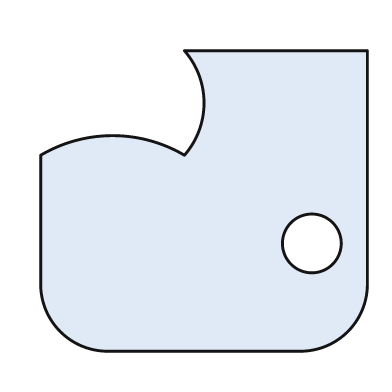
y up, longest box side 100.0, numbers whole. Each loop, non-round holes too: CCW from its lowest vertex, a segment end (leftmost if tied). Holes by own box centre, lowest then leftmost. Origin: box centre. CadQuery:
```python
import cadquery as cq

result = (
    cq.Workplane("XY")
    .moveTo(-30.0, -46.0)
    .lineTo(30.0, -46.0)
    .threePointArc((44.0, -40.0), (50.0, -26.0))
    .lineTo(50.0, 46.0)
    .lineTo(-6.0, 46.0)
    .threePointArc((0.0, 30.0), (-6.0, 14.0))
    .threePointArc((-28.0, 20.0), (-50.0, 14.0))
    .lineTo(-50.0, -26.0)
    .threePointArc((-44.0, -40.0), (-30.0, -46.0))
    .close()
    .moveTo(33.0, -13.0)
    .circle(9.0)
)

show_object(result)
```